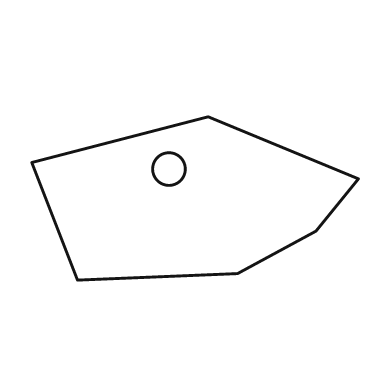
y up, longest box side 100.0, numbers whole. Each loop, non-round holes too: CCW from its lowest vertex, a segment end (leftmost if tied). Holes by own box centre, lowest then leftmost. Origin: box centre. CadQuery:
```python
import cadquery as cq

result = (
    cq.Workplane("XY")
    .moveTo(-36.0, -25.0)
    .lineTo(13.0, -23.0)
    .lineTo(37.0, -10.0)
    .lineTo(50.0, 6.0)
    .lineTo(4.0, 25.0)
    .lineTo(-50.0, 11.0)
    .close()
    .moveTo(-8.0, 9.0)
    .circle(5.0)
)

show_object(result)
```